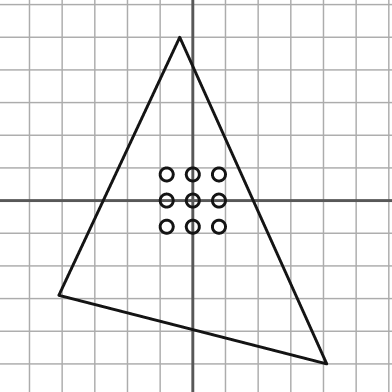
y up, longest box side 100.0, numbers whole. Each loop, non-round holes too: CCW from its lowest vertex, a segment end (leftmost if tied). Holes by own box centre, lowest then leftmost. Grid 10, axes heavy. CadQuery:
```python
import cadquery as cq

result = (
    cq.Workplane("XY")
    .moveTo(41.0, -50.0)
    .lineTo(-4.0, 50.0)
    .lineTo(-41.0, -29.0)
    .close()
    .moveTo(-8.0, -8.0)
    .circle(2.0)
    .moveTo(0.0, -8.0)
    .circle(2.0)
    .moveTo(8.0, -8.0)
    .circle(2.0)
    .moveTo(-8.0, 0.0)
    .circle(2.0)
    .moveTo(0.0, 0.0)
    .circle(2.0)
    .moveTo(8.0, 0.0)
    .circle(2.0)
    .moveTo(-8.0, 8.0)
    .circle(2.0)
    .moveTo(0.0, 8.0)
    .circle(2.0)
    .moveTo(8.0, 8.0)
    .circle(2.0)
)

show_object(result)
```